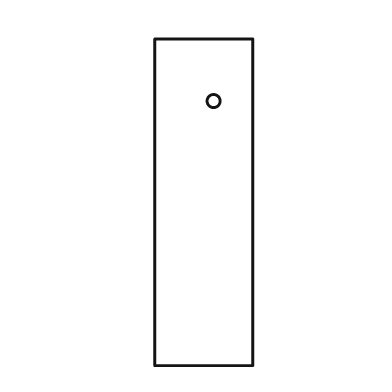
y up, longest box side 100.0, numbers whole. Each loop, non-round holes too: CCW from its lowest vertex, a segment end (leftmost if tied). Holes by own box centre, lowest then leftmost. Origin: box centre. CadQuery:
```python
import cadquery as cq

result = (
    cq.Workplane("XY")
    .moveTo(-15.0, -50.0)
    .lineTo(15.0, -50.0)
    .lineTo(15.0, 50.0)
    .lineTo(-15.0, 50.0)
    .close()
    .moveTo(3.0, 31.0)
    .circle(2.0)
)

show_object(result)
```